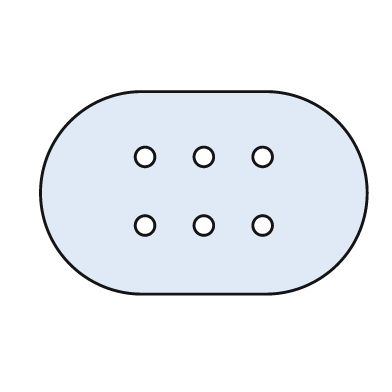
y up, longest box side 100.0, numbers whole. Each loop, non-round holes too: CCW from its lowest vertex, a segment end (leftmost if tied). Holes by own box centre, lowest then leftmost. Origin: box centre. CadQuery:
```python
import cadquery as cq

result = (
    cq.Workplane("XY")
    .moveTo(-19.0, -31.0)
    .lineTo(19.0, -31.0)
    .threePointArc((50.0, 0.0), (19.0, 31.0))
    .lineTo(-19.0, 31.0)
    .threePointArc((-50.0, 0.0), (-19.0, -31.0))
    .close()
    .moveTo(-18.0, -10.0)
    .circle(3.0)
    .moveTo(0.0, -10.0)
    .circle(3.0)
    .moveTo(18.0, -10.0)
    .circle(3.0)
    .moveTo(-18.0, 11.0)
    .circle(3.0)
    .moveTo(0.0, 11.0)
    .circle(3.0)
    .moveTo(18.0, 11.0)
    .circle(3.0)
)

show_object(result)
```